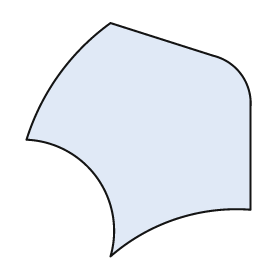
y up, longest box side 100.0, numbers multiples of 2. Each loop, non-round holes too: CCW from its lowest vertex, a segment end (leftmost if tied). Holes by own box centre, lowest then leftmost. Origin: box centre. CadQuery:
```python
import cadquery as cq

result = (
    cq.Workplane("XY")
    .moveTo(-12.0, -50.0)
    .threePointArc((16.0, -34.0), (48.0, -30.0))
    .lineTo(48.0, 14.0)
    .threePointArc((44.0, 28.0), (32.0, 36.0))
    .lineTo(-12.0, 50.0)
    .threePointArc((-34.0, 28.0), (-48.0, 0.0))
    .threePointArc((-18.0, -16.0), (-12.0, -50.0))
    .close()
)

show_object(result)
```